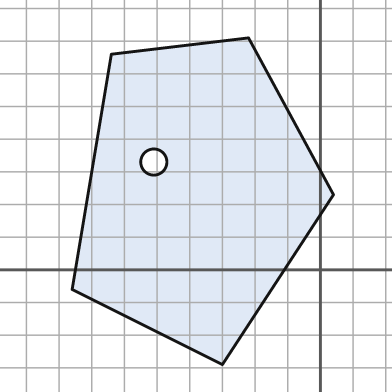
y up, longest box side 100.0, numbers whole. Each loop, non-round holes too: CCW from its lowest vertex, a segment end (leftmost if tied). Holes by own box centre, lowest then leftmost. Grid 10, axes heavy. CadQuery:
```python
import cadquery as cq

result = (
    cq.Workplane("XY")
    .moveTo(-30.0, -29.0)
    .lineTo(4.0, 23.0)
    .lineTo(-22.0, 71.0)
    .lineTo(-64.0, 66.0)
    .lineTo(-76.0, -6.0)
    .close()
    .moveTo(-51.0, 33.0)
    .circle(4.0)
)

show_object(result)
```